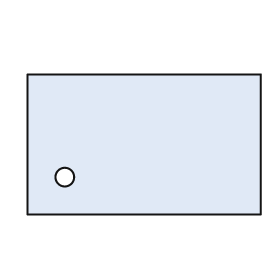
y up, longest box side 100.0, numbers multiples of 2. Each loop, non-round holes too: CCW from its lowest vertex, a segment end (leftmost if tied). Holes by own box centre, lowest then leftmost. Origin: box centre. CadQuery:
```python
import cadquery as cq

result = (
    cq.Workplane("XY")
    .moveTo(-50.0, -30.0)
    .lineTo(50.0, -30.0)
    .lineTo(50.0, 30.0)
    .lineTo(-50.0, 30.0)
    .close()
    .moveTo(-34.0, -14.0)
    .circle(4.0)
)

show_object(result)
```